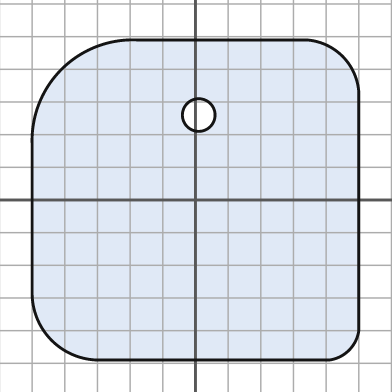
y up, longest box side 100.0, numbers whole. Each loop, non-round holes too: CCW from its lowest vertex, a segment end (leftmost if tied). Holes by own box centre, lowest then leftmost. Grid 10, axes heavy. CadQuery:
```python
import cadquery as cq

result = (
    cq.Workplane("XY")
    .moveTo(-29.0, -49.0)
    .lineTo(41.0, -49.0)
    .threePointArc((47.0, -46.0), (50.0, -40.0))
    .lineTo(50.0, 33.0)
    .threePointArc((45.0, 44.0), (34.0, 49.0))
    .lineTo(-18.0, 49.0)
    .threePointArc((-41.0, 40.0), (-50.0, 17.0))
    .lineTo(-50.0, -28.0)
    .threePointArc((-44.0, -43.0), (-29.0, -49.0))
    .close()
    .moveTo(1.0, 26.0)
    .circle(5.0)
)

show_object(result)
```